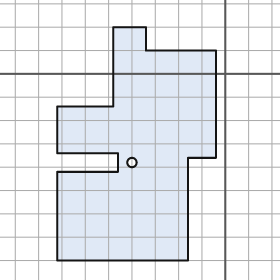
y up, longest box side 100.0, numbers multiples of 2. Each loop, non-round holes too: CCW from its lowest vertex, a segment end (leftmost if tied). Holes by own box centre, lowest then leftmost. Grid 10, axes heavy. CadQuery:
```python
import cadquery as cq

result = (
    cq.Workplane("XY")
    .moveTo(-72.0, -80.0)
    .lineTo(-16.0, -80.0)
    .lineTo(-16.0, -36.0)
    .lineTo(-4.0, -36.0)
    .lineTo(-4.0, 10.0)
    .lineTo(-34.0, 10.0)
    .lineTo(-34.0, 20.0)
    .lineTo(-48.0, 20.0)
    .lineTo(-48.0, -14.0)
    .lineTo(-72.0, -14.0)
    .lineTo(-72.0, -34.0)
    .lineTo(-46.0, -34.0)
    .lineTo(-46.0, -42.0)
    .lineTo(-72.0, -42.0)
    .close()
    .moveTo(-40.0, -38.0)
    .circle(2.0)
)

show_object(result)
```